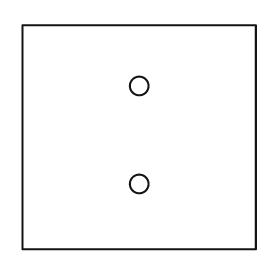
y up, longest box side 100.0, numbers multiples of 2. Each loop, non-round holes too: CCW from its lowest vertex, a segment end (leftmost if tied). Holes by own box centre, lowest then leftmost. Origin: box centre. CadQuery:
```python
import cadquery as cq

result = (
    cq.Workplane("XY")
    .moveTo(-50.0, -48.0)
    .lineTo(50.0, -48.0)
    .lineTo(50.0, 48.0)
    .lineTo(-50.0, 48.0)
    .close()
    .moveTo(0.0, -20.0)
    .circle(4.0)
    .moveTo(0.0, 22.0)
    .circle(4.0)
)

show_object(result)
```